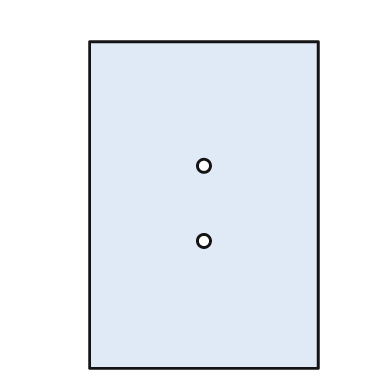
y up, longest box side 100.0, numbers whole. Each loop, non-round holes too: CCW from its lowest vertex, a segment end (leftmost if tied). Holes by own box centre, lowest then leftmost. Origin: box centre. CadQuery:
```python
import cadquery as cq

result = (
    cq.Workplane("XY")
    .moveTo(-35.0, -50.0)
    .lineTo(35.0, -50.0)
    .lineTo(35.0, 50.0)
    .lineTo(-35.0, 50.0)
    .close()
    .moveTo(0.0, -11.0)
    .circle(2.0)
    .moveTo(0.0, 12.0)
    .circle(2.0)
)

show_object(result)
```